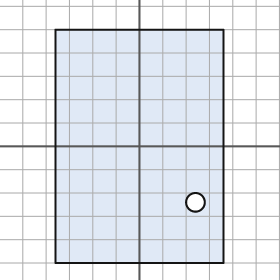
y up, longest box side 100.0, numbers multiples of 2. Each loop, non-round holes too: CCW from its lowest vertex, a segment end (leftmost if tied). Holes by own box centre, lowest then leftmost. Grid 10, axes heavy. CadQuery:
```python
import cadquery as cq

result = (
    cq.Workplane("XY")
    .moveTo(-36.0, -50.0)
    .lineTo(36.0, -50.0)
    .lineTo(36.0, 50.0)
    .lineTo(-36.0, 50.0)
    .close()
    .moveTo(24.0, -24.0)
    .circle(4.0)
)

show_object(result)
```